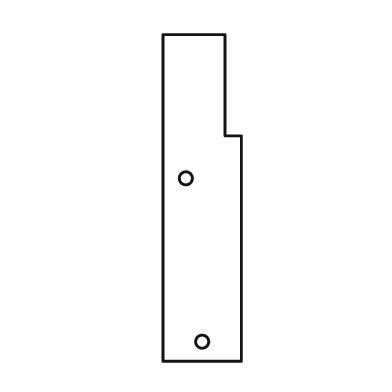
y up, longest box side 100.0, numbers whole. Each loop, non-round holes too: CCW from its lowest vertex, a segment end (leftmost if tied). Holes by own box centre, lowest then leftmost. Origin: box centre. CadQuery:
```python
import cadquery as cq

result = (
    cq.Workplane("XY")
    .moveTo(-12.0, -50.0)
    .lineTo(12.0, -50.0)
    .lineTo(12.0, 19.0)
    .lineTo(7.0, 19.0)
    .lineTo(7.0, 50.0)
    .lineTo(-12.0, 50.0)
    .close()
    .moveTo(0.0, -44.0)
    .circle(2.0)
    .moveTo(-5.0, 6.0)
    .circle(2.0)
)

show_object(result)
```